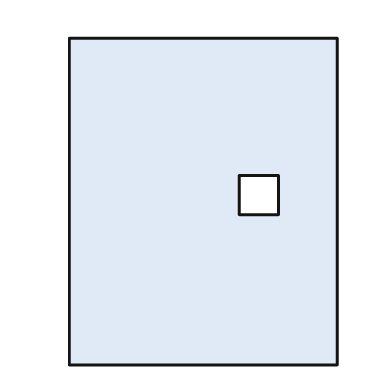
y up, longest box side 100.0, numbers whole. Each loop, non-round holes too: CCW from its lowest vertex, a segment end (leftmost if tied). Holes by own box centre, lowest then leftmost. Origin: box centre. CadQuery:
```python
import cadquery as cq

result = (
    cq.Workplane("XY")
    .moveTo(-41.0, -50.0)
    .lineTo(41.0, -50.0)
    .lineTo(41.0, 50.0)
    .lineTo(-41.0, 50.0)
    .close()
    .moveTo(11.0, -4.0)
    .lineTo(23.0, -4.0)
    .lineTo(23.0, 8.0)
    .lineTo(11.0, 8.0)
    .close()
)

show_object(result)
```